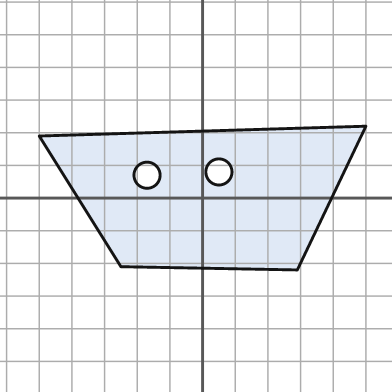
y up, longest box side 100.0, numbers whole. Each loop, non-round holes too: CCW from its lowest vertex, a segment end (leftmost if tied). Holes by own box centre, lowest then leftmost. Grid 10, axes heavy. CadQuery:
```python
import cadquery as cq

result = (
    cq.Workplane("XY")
    .moveTo(29.0, -22.0)
    .lineTo(50.0, 22.0)
    .lineTo(-50.0, 19.0)
    .lineTo(-25.0, -21.0)
    .close()
    .moveTo(-17.0, 7.0)
    .circle(4.0)
    .moveTo(5.0, 8.0)
    .circle(4.0)
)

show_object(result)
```